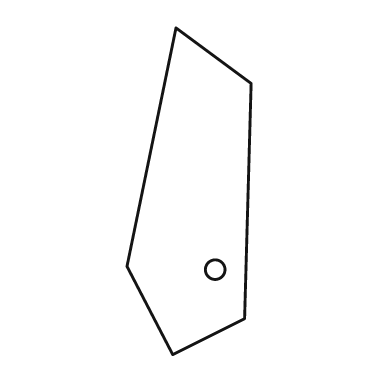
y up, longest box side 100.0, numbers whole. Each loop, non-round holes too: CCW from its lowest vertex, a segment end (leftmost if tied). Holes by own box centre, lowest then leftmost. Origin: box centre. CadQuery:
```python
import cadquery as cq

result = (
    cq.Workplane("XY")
    .moveTo(-5.0, -50.0)
    .lineTo(17.0, -39.0)
    .lineTo(19.0, 33.0)
    .lineTo(-4.0, 50.0)
    .lineTo(-19.0, -23.0)
    .close()
    .moveTo(8.0, -24.0)
    .circle(3.0)
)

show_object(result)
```